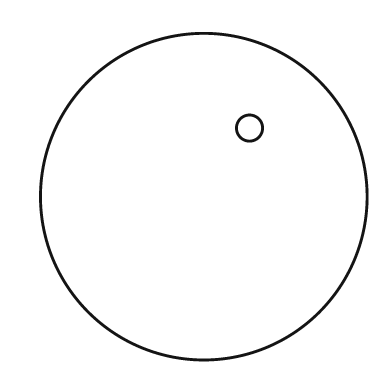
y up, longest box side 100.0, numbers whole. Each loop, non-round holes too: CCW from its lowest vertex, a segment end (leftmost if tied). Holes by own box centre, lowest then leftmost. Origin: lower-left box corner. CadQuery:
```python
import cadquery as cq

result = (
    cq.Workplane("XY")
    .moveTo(50.0, 50.0)
    .circle(50.0)
    .moveTo(64.0, 71.0)
    .circle(4.0)
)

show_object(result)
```